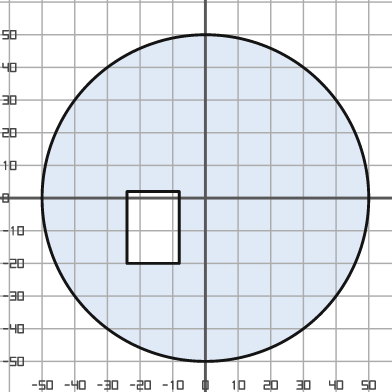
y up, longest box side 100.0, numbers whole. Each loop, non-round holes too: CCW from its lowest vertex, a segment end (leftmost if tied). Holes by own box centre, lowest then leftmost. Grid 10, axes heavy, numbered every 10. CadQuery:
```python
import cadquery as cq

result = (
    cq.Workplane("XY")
    .moveTo(0.0, 0.0)
    .circle(50.0)
    .moveTo(-24.0, -20.0)
    .lineTo(-8.0, -20.0)
    .lineTo(-8.0, 2.0)
    .lineTo(-24.0, 2.0)
    .close()
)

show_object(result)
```